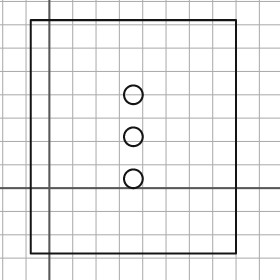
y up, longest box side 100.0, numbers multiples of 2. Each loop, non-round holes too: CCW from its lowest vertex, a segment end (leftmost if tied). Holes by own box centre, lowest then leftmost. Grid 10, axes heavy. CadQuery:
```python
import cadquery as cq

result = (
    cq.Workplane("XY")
    .moveTo(-8.0, -28.0)
    .lineTo(80.0, -28.0)
    .lineTo(80.0, 72.0)
    .lineTo(-8.0, 72.0)
    .close()
    .moveTo(36.0, 4.0)
    .circle(4.0)
    .moveTo(36.0, 22.0)
    .circle(4.0)
    .moveTo(36.0, 40.0)
    .circle(4.0)
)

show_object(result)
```